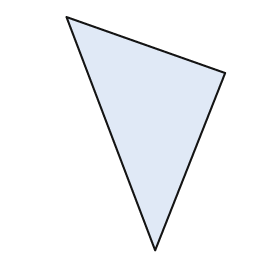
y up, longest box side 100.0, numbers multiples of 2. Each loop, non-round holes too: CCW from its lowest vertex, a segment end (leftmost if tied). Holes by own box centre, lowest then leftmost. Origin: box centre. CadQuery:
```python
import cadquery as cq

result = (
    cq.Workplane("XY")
    .moveTo(4.0, -50.0)
    .lineTo(34.0, 26.0)
    .lineTo(-34.0, 50.0)
    .close()
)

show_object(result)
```